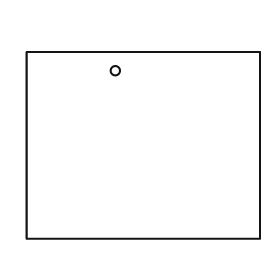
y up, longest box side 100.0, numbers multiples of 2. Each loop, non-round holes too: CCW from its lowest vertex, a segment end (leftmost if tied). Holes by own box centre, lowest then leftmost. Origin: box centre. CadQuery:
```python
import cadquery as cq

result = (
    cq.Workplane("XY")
    .moveTo(-50.0, -40.0)
    .lineTo(50.0, -40.0)
    .lineTo(50.0, 40.0)
    .lineTo(-50.0, 40.0)
    .close()
    .moveTo(-12.0, 32.0)
    .circle(2.0)
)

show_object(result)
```